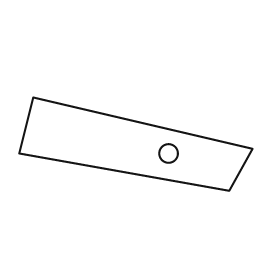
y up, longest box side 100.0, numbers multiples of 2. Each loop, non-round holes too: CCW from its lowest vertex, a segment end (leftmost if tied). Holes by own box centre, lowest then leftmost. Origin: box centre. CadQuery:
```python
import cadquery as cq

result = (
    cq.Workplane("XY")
    .moveTo(40.0, -20.0)
    .lineTo(50.0, -2.0)
    .lineTo(-44.0, 20.0)
    .lineTo(-50.0, -4.0)
    .close()
    .moveTo(14.0, -4.0)
    .circle(4.0)
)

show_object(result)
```